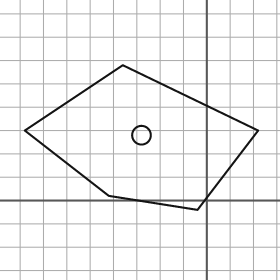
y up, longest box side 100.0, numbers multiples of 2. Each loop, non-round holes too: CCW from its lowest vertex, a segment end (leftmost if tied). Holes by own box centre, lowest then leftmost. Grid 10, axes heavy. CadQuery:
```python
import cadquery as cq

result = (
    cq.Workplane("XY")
    .moveTo(-4.0, -4.0)
    .lineTo(22.0, 30.0)
    .lineTo(-36.0, 58.0)
    .lineTo(-78.0, 30.0)
    .lineTo(-42.0, 2.0)
    .close()
    .moveTo(-28.0, 28.0)
    .circle(4.0)
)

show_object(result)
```